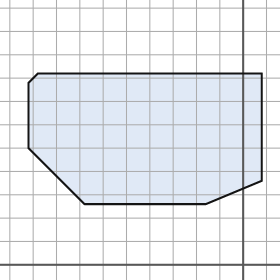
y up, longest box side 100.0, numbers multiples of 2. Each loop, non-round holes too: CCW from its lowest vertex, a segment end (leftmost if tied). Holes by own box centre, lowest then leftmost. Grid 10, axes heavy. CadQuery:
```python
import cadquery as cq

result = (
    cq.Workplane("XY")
    .moveTo(-68.0, 26.0)
    .lineTo(-16.0, 26.0)
    .lineTo(8.0, 36.0)
    .lineTo(8.0, 82.0)
    .lineTo(-88.0, 82.0)
    .lineTo(-92.0, 78.0)
    .lineTo(-92.0, 50.0)
    .close()
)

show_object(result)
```